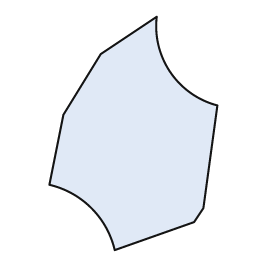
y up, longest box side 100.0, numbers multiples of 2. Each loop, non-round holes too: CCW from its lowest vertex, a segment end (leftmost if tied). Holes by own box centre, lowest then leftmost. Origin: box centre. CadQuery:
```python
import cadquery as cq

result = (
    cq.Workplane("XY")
    .moveTo(-8.0, -50.0)
    .lineTo(26.0, -38.0)
    .lineTo(30.0, -32.0)
    .lineTo(36.0, 12.0)
    .threePointArc((16.0, 26.0), (10.0, 50.0))
    .lineTo(-14.0, 34.0)
    .lineTo(-30.0, 8.0)
    .lineTo(-36.0, -22.0)
    .threePointArc((-18.0, -32.0), (-8.0, -50.0))
    .close()
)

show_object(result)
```